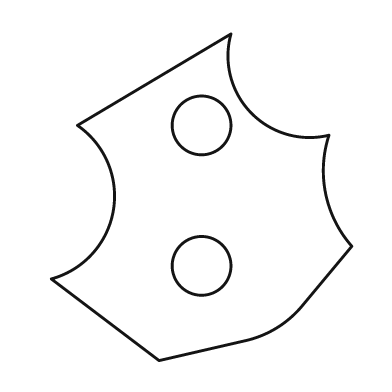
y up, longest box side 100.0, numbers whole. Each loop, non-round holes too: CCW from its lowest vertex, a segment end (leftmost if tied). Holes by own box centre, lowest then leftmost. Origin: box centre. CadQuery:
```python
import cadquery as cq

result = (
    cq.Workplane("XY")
    .moveTo(-13.0, -50.0)
    .lineTo(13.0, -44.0)
    .threePointArc((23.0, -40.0), (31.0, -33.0))
    .lineTo(46.0, -15.0)
    .threePointArc((38.0, 1.0), (39.0, 19.0))
    .threePointArc((15.0, 26.0), (9.0, 50.0))
    .lineTo(-38.0, 22.0)
    .threePointArc((-27.0, -4.0), (-46.0, -25.0))
    .close()
    .moveTo(0.0, -21.0)
    .circle(9.0)
    .moveTo(0.0, 22.0)
    .circle(9.0)
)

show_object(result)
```